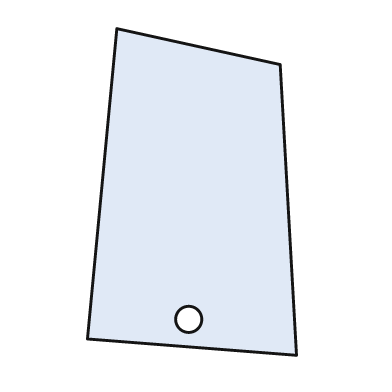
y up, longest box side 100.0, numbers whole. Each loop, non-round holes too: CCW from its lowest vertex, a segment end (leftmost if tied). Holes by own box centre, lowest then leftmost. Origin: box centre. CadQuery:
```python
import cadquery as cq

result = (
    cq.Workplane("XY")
    .moveTo(32.0, -50.0)
    .lineTo(27.0, 39.0)
    .lineTo(-23.0, 50.0)
    .lineTo(-32.0, -45.0)
    .close()
    .moveTo(-1.0, -39.0)
    .circle(4.0)
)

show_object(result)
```